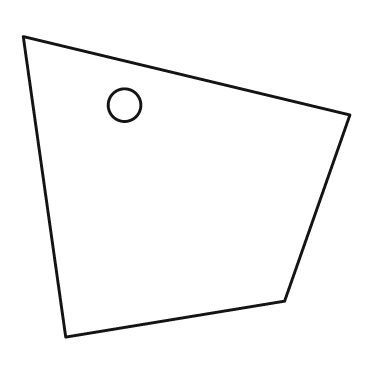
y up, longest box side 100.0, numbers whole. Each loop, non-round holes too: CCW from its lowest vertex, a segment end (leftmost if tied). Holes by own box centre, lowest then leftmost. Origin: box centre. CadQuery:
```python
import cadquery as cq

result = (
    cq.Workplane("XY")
    .moveTo(-37.0, -46.0)
    .lineTo(30.0, -35.0)
    .lineTo(50.0, 22.0)
    .lineTo(-50.0, 46.0)
    .close()
    .moveTo(-19.0, 25.0)
    .circle(5.0)
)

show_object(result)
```